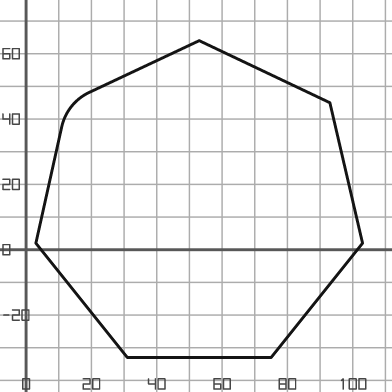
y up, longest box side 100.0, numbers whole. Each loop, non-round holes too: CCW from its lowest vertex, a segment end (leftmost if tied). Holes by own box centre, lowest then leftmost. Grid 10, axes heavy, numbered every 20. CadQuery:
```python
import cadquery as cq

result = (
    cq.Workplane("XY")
    .moveTo(31.0, -33.0)
    .lineTo(75.0, -33.0)
    .lineTo(103.0, 2.0)
    .lineTo(93.0, 45.0)
    .lineTo(53.0, 64.0)
    .lineTo(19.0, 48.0)
    .threePointArc((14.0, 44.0), (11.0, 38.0))
    .lineTo(3.0, 2.0)
    .close()
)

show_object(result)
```